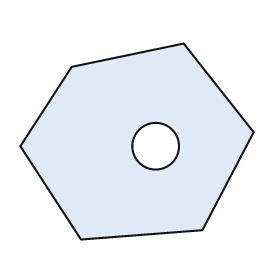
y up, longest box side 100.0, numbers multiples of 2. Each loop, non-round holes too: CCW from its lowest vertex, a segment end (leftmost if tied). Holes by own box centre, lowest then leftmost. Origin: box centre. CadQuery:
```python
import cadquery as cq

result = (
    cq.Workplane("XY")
    .moveTo(-24.0, -42.0)
    .lineTo(28.0, -38.0)
    .lineTo(50.0, 4.0)
    .lineTo(20.0, 42.0)
    .lineTo(-28.0, 32.0)
    .lineTo(-50.0, -2.0)
    .close()
    .moveTo(8.0, -2.0)
    .circle(10.0)
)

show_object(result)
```